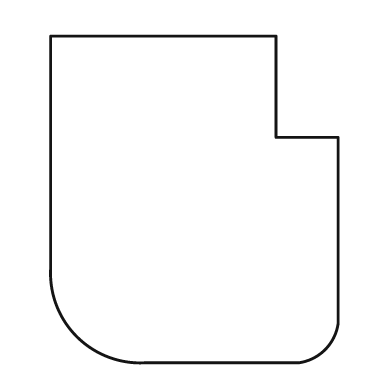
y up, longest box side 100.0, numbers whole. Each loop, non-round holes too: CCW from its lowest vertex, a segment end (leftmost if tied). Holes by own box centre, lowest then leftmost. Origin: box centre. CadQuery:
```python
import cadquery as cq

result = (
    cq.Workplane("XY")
    .moveTo(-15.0, -50.0)
    .lineTo(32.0, -50.0)
    .threePointArc((40.0, -46.0), (44.0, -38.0))
    .lineTo(44.0, 19.0)
    .lineTo(25.0, 19.0)
    .lineTo(25.0, 50.0)
    .lineTo(-44.0, 50.0)
    .lineTo(-44.0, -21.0)
    .threePointArc((-36.0, -42.0), (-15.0, -50.0))
    .close()
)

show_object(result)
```